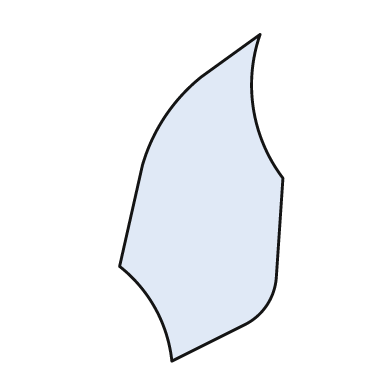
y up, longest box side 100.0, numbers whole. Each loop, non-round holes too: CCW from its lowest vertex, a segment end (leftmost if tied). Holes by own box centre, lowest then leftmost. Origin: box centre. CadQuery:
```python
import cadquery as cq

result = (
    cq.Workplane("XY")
    .moveTo(-9.0, -50.0)
    .lineTo(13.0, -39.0)
    .threePointArc((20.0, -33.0), (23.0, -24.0))
    .lineTo(25.0, 6.0)
    .threePointArc((16.0, 27.0), (18.0, 50.0))
    .lineTo(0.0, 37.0)
    .threePointArc((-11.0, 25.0), (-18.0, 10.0))
    .lineTo(-25.0, -21.0)
    .threePointArc((-14.0, -34.0), (-9.0, -50.0))
    .close()
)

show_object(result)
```